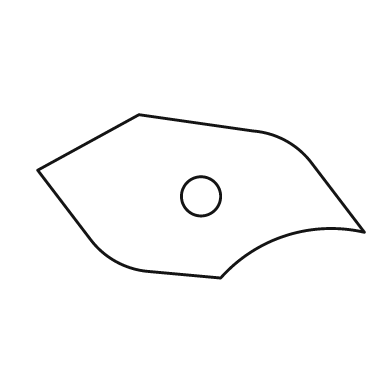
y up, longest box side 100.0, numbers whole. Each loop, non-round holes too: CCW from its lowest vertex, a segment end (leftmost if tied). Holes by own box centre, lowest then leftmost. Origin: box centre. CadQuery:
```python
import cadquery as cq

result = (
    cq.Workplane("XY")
    .moveTo(6.0, -25.0)
    .threePointArc((26.0, -12.0), (50.0, -11.0))
    .lineTo(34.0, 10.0)
    .threePointArc((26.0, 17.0), (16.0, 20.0))
    .lineTo(-19.0, 25.0)
    .lineTo(-50.0, 8.0)
    .lineTo(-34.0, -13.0)
    .threePointArc((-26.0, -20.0), (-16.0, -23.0))
    .close()
    .moveTo(0.0, 0.0)
    .circle(6.0)
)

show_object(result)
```